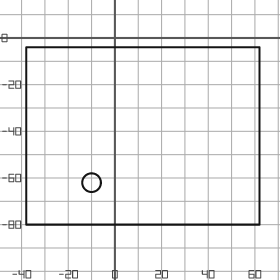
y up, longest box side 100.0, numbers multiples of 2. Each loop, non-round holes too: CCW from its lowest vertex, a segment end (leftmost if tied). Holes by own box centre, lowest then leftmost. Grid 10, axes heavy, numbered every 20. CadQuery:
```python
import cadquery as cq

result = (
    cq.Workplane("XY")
    .moveTo(-38.0, -80.0)
    .lineTo(62.0, -80.0)
    .lineTo(62.0, -4.0)
    .lineTo(-38.0, -4.0)
    .close()
    .moveTo(-10.0, -62.0)
    .circle(4.0)
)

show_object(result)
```